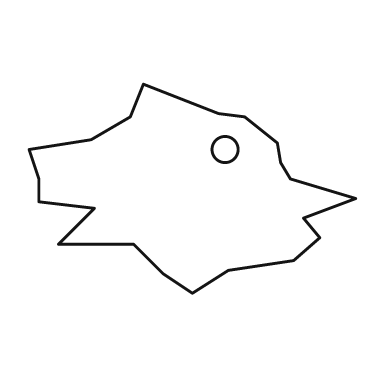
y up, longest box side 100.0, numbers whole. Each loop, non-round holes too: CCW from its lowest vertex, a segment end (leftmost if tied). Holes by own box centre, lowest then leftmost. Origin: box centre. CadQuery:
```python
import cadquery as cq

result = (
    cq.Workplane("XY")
    .moveTo(0.0, -32.0)
    .lineTo(11.0, -25.0)
    .lineTo(31.0, -22.0)
    .lineTo(39.0, -15.0)
    .lineTo(34.0, -9.0)
    .lineTo(50.0, -3.0)
    .lineTo(30.0, 3.0)
    .lineTo(27.0, 8.0)
    .lineTo(26.0, 14.0)
    .lineTo(16.0, 22.0)
    .lineTo(8.0, 23.0)
    .lineTo(-15.0, 32.0)
    .lineTo(-19.0, 22.0)
    .lineTo(-31.0, 15.0)
    .lineTo(-50.0, 12.0)
    .lineTo(-47.0, 3.0)
    .lineTo(-47.0, -4.0)
    .lineTo(-30.0, -6.0)
    .lineTo(-41.0, -17.0)
    .lineTo(-18.0, -17.0)
    .lineTo(-9.0, -26.0)
    .close()
    .moveTo(10.0, 12.0)
    .circle(4.0)
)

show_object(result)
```